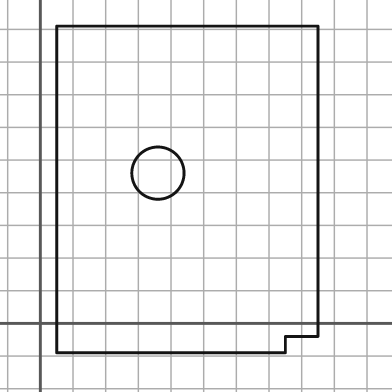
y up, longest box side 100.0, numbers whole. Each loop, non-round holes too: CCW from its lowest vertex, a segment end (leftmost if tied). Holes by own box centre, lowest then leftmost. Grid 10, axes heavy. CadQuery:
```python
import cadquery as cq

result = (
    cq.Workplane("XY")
    .moveTo(5.0, -9.0)
    .lineTo(75.0, -9.0)
    .lineTo(75.0, -4.0)
    .lineTo(85.0, -4.0)
    .lineTo(85.0, 91.0)
    .lineTo(5.0, 91.0)
    .close()
    .moveTo(36.0, 46.0)
    .circle(8.0)
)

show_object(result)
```